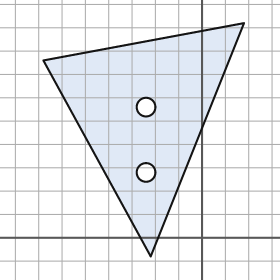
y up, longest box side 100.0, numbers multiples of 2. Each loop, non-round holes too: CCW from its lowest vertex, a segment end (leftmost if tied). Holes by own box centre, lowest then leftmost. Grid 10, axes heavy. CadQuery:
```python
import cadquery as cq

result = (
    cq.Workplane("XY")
    .moveTo(-22.0, -8.0)
    .lineTo(18.0, 92.0)
    .lineTo(-68.0, 76.0)
    .close()
    .moveTo(-24.0, 28.0)
    .circle(4.0)
    .moveTo(-24.0, 56.0)
    .circle(4.0)
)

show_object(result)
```